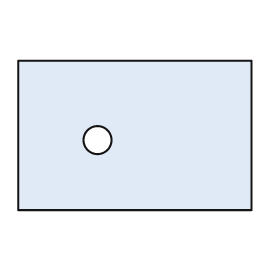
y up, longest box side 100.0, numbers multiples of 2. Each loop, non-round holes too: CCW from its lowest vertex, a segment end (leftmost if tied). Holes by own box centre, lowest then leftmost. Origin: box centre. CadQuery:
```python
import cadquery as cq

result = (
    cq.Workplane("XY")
    .moveTo(-50.0, -32.0)
    .lineTo(50.0, -32.0)
    .lineTo(50.0, 32.0)
    .lineTo(-50.0, 32.0)
    .close()
    .moveTo(-16.0, -2.0)
    .circle(6.0)
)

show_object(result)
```